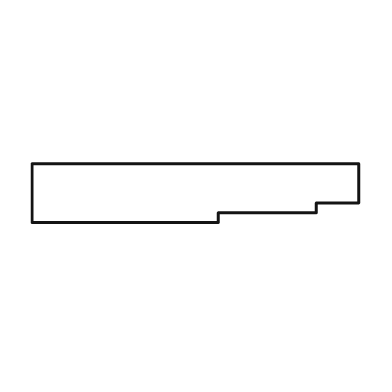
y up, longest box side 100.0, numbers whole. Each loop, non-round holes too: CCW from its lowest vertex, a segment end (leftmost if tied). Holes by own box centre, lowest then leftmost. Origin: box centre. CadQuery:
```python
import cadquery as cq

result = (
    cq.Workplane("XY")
    .moveTo(-50.0, -9.0)
    .lineTo(7.0, -9.0)
    .lineTo(7.0, -6.0)
    .lineTo(37.0, -6.0)
    .lineTo(37.0, -3.0)
    .lineTo(50.0, -3.0)
    .lineTo(50.0, 9.0)
    .lineTo(-50.0, 9.0)
    .close()
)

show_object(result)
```